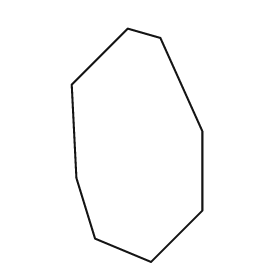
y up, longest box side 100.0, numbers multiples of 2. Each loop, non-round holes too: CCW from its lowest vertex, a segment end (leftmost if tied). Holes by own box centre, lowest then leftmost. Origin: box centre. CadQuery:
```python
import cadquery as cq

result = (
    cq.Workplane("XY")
    .moveTo(6.0, -50.0)
    .lineTo(28.0, -28.0)
    .lineTo(28.0, 6.0)
    .lineTo(10.0, 46.0)
    .lineTo(-4.0, 50.0)
    .lineTo(-28.0, 26.0)
    .lineTo(-26.0, -14.0)
    .lineTo(-18.0, -40.0)
    .close()
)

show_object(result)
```